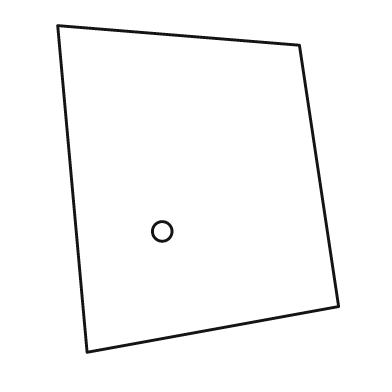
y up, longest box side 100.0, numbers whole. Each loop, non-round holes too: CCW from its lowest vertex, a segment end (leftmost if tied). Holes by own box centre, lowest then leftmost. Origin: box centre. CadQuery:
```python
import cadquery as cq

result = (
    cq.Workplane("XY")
    .moveTo(-34.0, -50.0)
    .lineTo(43.0, -36.0)
    .lineTo(31.0, 44.0)
    .lineTo(-43.0, 50.0)
    .close()
    .moveTo(-11.0, -13.0)
    .circle(3.0)
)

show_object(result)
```